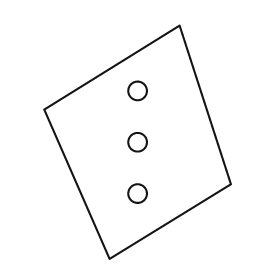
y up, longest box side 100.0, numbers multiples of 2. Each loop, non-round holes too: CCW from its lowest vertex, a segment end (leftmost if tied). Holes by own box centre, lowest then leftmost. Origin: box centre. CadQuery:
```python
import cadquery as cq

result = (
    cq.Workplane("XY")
    .moveTo(-12.0, -50.0)
    .lineTo(40.0, -18.0)
    .lineTo(18.0, 50.0)
    .lineTo(-40.0, 14.0)
    .close()
    .moveTo(0.0, -22.0)
    .circle(4.0)
    .moveTo(0.0, 0.0)
    .circle(4.0)
    .moveTo(0.0, 22.0)
    .circle(4.0)
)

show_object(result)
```